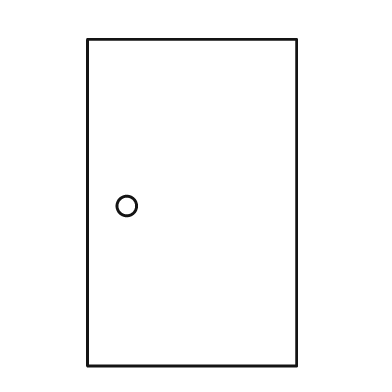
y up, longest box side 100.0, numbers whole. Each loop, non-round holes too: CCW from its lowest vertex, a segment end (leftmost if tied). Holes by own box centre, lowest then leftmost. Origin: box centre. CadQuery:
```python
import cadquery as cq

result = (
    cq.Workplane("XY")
    .moveTo(-32.0, -50.0)
    .lineTo(32.0, -50.0)
    .lineTo(32.0, 50.0)
    .lineTo(-32.0, 50.0)
    .close()
    .moveTo(-20.0, -1.0)
    .circle(3.0)
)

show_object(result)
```